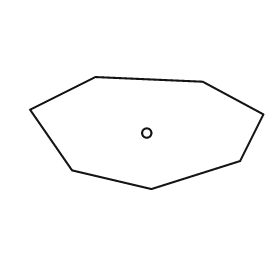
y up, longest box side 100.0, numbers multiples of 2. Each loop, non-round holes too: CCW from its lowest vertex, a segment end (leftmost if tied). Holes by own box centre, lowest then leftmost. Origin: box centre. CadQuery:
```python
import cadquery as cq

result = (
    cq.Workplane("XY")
    .moveTo(2.0, -24.0)
    .lineTo(40.0, -12.0)
    .lineTo(50.0, 8.0)
    .lineTo(24.0, 22.0)
    .lineTo(-22.0, 24.0)
    .lineTo(-50.0, 10.0)
    .lineTo(-32.0, -16.0)
    .close()
    .moveTo(0.0, 0.0)
    .circle(2.0)
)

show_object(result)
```